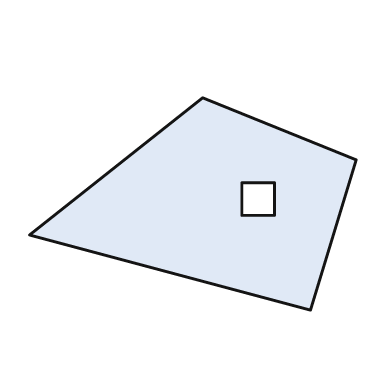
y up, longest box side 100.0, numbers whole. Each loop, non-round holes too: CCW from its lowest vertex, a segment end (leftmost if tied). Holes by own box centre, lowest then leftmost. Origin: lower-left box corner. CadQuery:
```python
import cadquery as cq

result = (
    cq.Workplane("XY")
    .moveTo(86.0, 0.0)
    .lineTo(100.0, 46.0)
    .lineTo(53.0, 65.0)
    .lineTo(0.0, 23.0)
    .close()
    .moveTo(65.0, 29.0)
    .lineTo(75.0, 29.0)
    .lineTo(75.0, 39.0)
    .lineTo(65.0, 39.0)
    .close()
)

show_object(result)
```